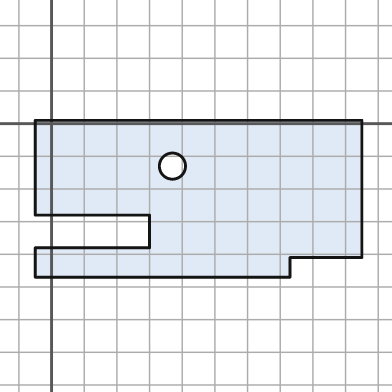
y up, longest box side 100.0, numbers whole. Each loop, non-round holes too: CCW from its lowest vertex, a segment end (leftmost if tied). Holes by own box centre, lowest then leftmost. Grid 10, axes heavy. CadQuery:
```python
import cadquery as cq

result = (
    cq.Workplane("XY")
    .moveTo(-5.0, -47.0)
    .lineTo(73.0, -47.0)
    .lineTo(73.0, -41.0)
    .lineTo(95.0, -41.0)
    .lineTo(95.0, 1.0)
    .lineTo(-5.0, 1.0)
    .lineTo(-5.0, -28.0)
    .lineTo(30.0, -28.0)
    .lineTo(30.0, -38.0)
    .lineTo(-5.0, -38.0)
    .close()
    .moveTo(37.0, -13.0)
    .circle(4.0)
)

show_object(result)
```